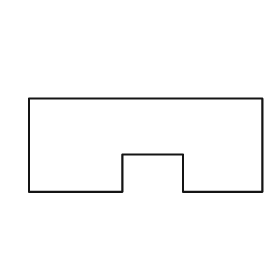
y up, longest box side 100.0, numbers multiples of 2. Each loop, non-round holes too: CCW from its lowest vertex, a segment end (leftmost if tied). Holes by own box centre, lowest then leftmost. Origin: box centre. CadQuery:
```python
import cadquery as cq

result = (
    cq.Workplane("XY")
    .moveTo(-50.0, -20.0)
    .lineTo(-10.0, -20.0)
    .lineTo(-10.0, -4.0)
    .lineTo(16.0, -4.0)
    .lineTo(16.0, -20.0)
    .lineTo(50.0, -20.0)
    .lineTo(50.0, 20.0)
    .lineTo(-50.0, 20.0)
    .close()
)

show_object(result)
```